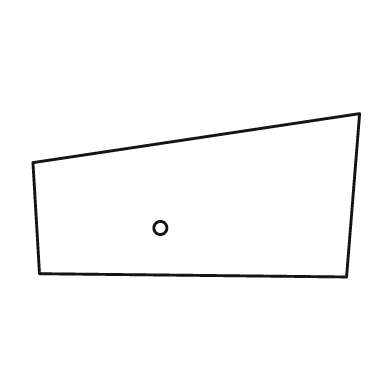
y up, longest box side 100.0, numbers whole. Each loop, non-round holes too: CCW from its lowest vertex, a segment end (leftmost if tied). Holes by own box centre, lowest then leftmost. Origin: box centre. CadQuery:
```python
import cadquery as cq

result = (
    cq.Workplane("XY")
    .moveTo(46.0, -25.0)
    .lineTo(50.0, 25.0)
    .lineTo(-50.0, 10.0)
    .lineTo(-48.0, -24.0)
    .close()
    .moveTo(-11.0, -10.0)
    .circle(2.0)
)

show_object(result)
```